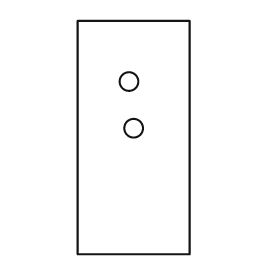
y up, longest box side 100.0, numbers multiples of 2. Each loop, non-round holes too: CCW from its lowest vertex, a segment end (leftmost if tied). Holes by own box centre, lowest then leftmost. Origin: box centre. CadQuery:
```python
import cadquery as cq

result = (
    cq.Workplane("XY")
    .moveTo(-24.0, -50.0)
    .lineTo(24.0, -50.0)
    .lineTo(24.0, 50.0)
    .lineTo(-24.0, 50.0)
    .close()
    .moveTo(0.0, 4.0)
    .circle(4.0)
    .moveTo(-2.0, 24.0)
    .circle(4.0)
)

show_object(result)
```